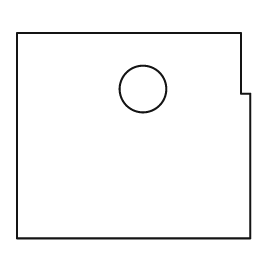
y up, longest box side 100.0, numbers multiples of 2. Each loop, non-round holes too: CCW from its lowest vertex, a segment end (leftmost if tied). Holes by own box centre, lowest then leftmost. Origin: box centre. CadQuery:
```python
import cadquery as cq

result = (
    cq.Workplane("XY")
    .moveTo(-50.0, -44.0)
    .lineTo(50.0, -44.0)
    .lineTo(50.0, 18.0)
    .lineTo(46.0, 18.0)
    .lineTo(46.0, 44.0)
    .lineTo(-50.0, 44.0)
    .close()
    .moveTo(4.0, 20.0)
    .circle(10.0)
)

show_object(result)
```